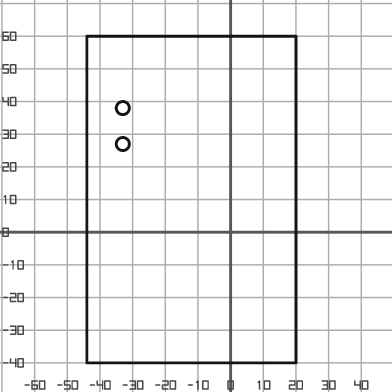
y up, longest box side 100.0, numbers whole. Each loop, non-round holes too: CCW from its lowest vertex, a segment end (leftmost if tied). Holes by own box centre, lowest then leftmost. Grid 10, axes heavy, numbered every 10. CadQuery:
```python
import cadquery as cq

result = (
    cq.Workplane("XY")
    .moveTo(-44.0, -40.0)
    .lineTo(20.0, -40.0)
    .lineTo(20.0, 60.0)
    .lineTo(-44.0, 60.0)
    .close()
    .moveTo(-33.0, 27.0)
    .circle(2.0)
    .moveTo(-33.0, 38.0)
    .circle(2.0)
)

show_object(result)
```